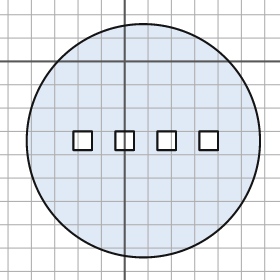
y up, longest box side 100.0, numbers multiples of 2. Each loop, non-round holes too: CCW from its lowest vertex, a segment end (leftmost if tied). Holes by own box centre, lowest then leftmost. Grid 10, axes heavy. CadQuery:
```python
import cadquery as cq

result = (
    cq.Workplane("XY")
    .moveTo(8.0, -34.0)
    .circle(50.0)
    .moveTo(-22.0, -38.0)
    .lineTo(-14.0, -38.0)
    .lineTo(-14.0, -30.0)
    .lineTo(-22.0, -30.0)
    .close()
    .moveTo(-4.0, -38.0)
    .lineTo(4.0, -38.0)
    .lineTo(4.0, -30.0)
    .lineTo(-4.0, -30.0)
    .close()
    .moveTo(14.0, -38.0)
    .lineTo(22.0, -38.0)
    .lineTo(22.0, -30.0)
    .lineTo(14.0, -30.0)
    .close()
    .moveTo(32.0, -38.0)
    .lineTo(40.0, -38.0)
    .lineTo(40.0, -30.0)
    .lineTo(32.0, -30.0)
    .close()
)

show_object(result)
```